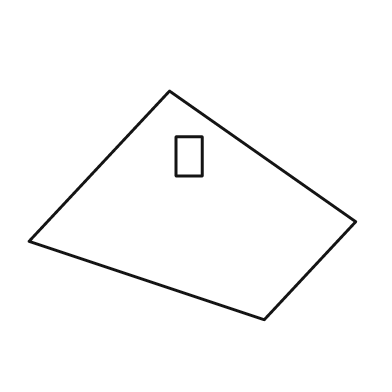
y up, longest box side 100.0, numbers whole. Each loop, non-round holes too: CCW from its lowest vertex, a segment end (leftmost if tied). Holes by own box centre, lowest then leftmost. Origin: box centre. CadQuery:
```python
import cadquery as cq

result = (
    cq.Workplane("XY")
    .moveTo(22.0, -35.0)
    .lineTo(50.0, -5.0)
    .lineTo(-7.0, 35.0)
    .lineTo(-50.0, -11.0)
    .close()
    .moveTo(-5.0, 9.0)
    .lineTo(3.0, 9.0)
    .lineTo(3.0, 21.0)
    .lineTo(-5.0, 21.0)
    .close()
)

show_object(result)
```